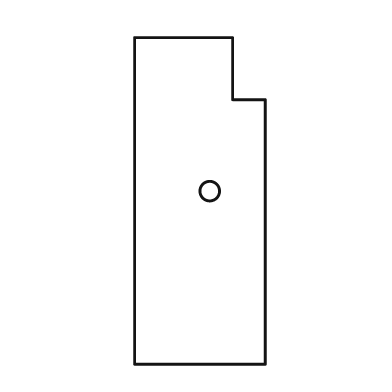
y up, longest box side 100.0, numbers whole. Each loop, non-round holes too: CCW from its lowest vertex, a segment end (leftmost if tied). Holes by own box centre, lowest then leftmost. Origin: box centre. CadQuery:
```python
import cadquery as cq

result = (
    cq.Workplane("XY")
    .moveTo(-20.0, -50.0)
    .lineTo(20.0, -50.0)
    .lineTo(20.0, 31.0)
    .lineTo(10.0, 31.0)
    .lineTo(10.0, 50.0)
    .lineTo(-20.0, 50.0)
    .close()
    .moveTo(3.0, 3.0)
    .circle(3.0)
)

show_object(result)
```